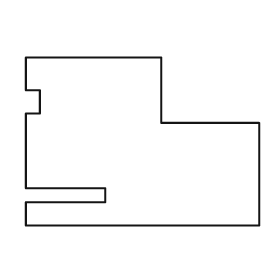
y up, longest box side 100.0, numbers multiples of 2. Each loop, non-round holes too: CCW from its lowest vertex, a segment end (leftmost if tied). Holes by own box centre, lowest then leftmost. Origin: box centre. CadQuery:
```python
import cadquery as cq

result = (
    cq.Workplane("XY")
    .moveTo(-50.0, -36.0)
    .lineTo(50.0, -36.0)
    .lineTo(50.0, 8.0)
    .lineTo(8.0, 8.0)
    .lineTo(8.0, 36.0)
    .lineTo(-50.0, 36.0)
    .lineTo(-50.0, 22.0)
    .lineTo(-44.0, 22.0)
    .lineTo(-44.0, 12.0)
    .lineTo(-50.0, 12.0)
    .lineTo(-50.0, -20.0)
    .lineTo(-16.0, -20.0)
    .lineTo(-16.0, -26.0)
    .lineTo(-50.0, -26.0)
    .close()
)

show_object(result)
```